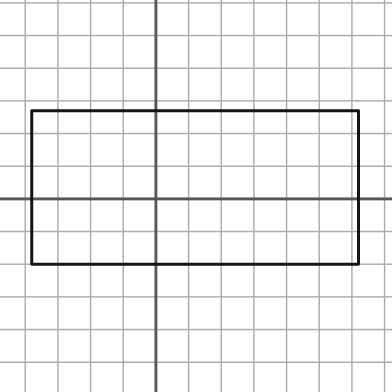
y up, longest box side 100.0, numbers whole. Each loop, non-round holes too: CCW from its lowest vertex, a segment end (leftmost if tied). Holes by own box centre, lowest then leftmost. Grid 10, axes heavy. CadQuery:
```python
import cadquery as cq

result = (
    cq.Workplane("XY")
    .moveTo(-38.0, -20.0)
    .lineTo(62.0, -20.0)
    .lineTo(62.0, 27.0)
    .lineTo(-38.0, 27.0)
    .close()
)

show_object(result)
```